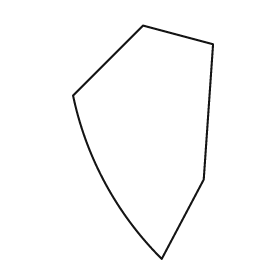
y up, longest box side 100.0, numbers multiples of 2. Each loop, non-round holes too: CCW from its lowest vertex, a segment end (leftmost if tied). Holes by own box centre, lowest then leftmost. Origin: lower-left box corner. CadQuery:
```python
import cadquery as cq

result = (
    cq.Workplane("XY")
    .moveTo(38.0, 0.0)
    .lineTo(56.0, 34.0)
    .lineTo(60.0, 92.0)
    .lineTo(30.0, 100.0)
    .lineTo(0.0, 70.0)
    .threePointArc((14.0, 32.0), (38.0, 0.0))
    .close()
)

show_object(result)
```